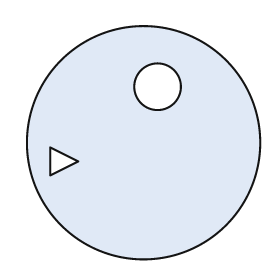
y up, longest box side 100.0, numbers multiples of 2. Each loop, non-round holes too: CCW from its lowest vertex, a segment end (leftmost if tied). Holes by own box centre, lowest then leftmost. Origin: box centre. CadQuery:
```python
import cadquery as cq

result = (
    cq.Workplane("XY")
    .moveTo(0.0, 0.0)
    .circle(50.0)
    .moveTo(-40.0, -14.0)
    .lineTo(-28.0, -8.0)
    .lineTo(-40.0, -2.0)
    .close()
    .moveTo(6.0, 24.0)
    .circle(10.0)
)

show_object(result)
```